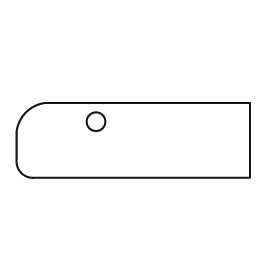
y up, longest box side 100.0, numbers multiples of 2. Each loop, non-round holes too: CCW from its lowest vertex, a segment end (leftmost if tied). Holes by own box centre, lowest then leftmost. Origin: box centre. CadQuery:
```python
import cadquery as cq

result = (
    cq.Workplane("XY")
    .moveTo(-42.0, -16.0)
    .lineTo(50.0, -16.0)
    .lineTo(50.0, 16.0)
    .lineTo(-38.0, 16.0)
    .threePointArc((-46.0, 12.0), (-50.0, 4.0))
    .lineTo(-50.0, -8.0)
    .threePointArc((-48.0, -14.0), (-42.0, -16.0))
    .close()
    .moveTo(-16.0, 8.0)
    .circle(4.0)
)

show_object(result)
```